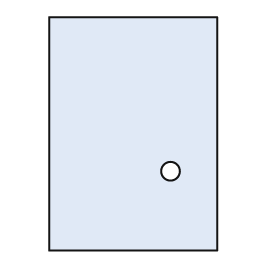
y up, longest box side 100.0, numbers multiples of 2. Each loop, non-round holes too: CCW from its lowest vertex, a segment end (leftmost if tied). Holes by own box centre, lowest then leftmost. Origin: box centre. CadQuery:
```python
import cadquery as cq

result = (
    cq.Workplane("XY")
    .moveTo(-36.0, -50.0)
    .lineTo(36.0, -50.0)
    .lineTo(36.0, 50.0)
    .lineTo(-36.0, 50.0)
    .close()
    .moveTo(16.0, -16.0)
    .circle(4.0)
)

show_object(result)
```